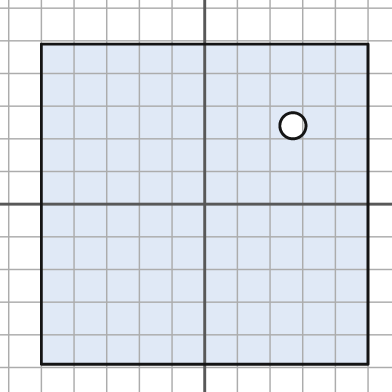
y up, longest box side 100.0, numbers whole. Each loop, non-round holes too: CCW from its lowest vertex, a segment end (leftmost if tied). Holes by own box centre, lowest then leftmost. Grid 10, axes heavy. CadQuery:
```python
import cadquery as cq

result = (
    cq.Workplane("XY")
    .moveTo(-50.0, -49.0)
    .lineTo(50.0, -49.0)
    .lineTo(50.0, 49.0)
    .lineTo(-50.0, 49.0)
    .close()
    .moveTo(27.0, 24.0)
    .circle(4.0)
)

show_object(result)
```